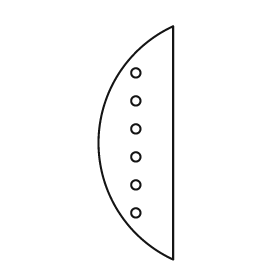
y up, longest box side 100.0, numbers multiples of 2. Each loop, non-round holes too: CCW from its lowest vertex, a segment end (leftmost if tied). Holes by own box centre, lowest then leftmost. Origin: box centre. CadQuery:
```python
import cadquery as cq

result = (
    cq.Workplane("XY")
    .moveTo(16.0, -50.0)
    .lineTo(16.0, 50.0)
    .threePointArc((-16.0, 0.0), (16.0, -50.0))
    .close()
    .moveTo(0.0, -30.0)
    .circle(2.0)
    .moveTo(0.0, -18.0)
    .circle(2.0)
    .moveTo(0.0, -6.0)
    .circle(2.0)
    .moveTo(0.0, 6.0)
    .circle(2.0)
    .moveTo(0.0, 18.0)
    .circle(2.0)
    .moveTo(0.0, 30.0)
    .circle(2.0)
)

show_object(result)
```